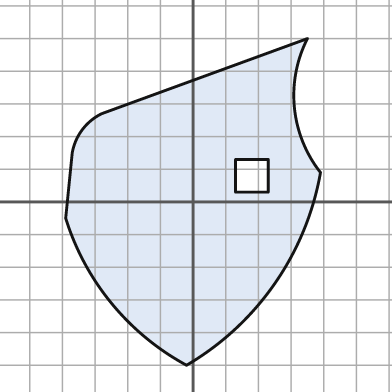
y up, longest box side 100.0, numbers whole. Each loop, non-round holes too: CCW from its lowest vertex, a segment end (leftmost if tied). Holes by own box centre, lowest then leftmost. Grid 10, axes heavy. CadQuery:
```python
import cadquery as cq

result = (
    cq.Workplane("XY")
    .moveTo(-2.0, -50.0)
    .threePointArc((25.0, -25.0), (39.0, 9.0))
    .threePointArc((31.0, 29.0), (35.0, 50.0))
    .lineTo(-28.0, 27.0)
    .threePointArc((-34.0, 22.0), (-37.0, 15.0))
    .lineTo(-39.0, -5.0)
    .threePointArc((-25.0, -31.0), (-2.0, -50.0))
    .close()
    .moveTo(13.0, 3.0)
    .lineTo(23.0, 3.0)
    .lineTo(23.0, 13.0)
    .lineTo(13.0, 13.0)
    .close()
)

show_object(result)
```